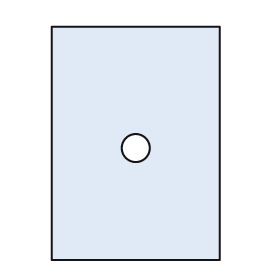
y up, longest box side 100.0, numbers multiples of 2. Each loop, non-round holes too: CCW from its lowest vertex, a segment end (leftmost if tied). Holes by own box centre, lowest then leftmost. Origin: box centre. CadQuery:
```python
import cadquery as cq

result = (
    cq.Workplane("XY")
    .moveTo(-36.0, -50.0)
    .lineTo(36.0, -50.0)
    .lineTo(36.0, 50.0)
    .lineTo(-36.0, 50.0)
    .close()
    .moveTo(0.0, -2.0)
    .circle(6.0)
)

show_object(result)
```